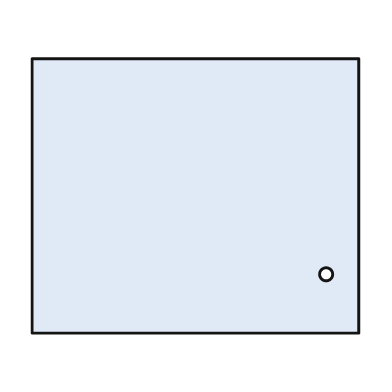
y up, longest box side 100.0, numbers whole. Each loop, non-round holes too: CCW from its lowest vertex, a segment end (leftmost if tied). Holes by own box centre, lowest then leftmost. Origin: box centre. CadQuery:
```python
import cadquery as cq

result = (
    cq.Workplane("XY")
    .moveTo(-50.0, -42.0)
    .lineTo(50.0, -42.0)
    .lineTo(50.0, 42.0)
    .lineTo(-50.0, 42.0)
    .close()
    .moveTo(40.0, -24.0)
    .circle(2.0)
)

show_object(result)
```